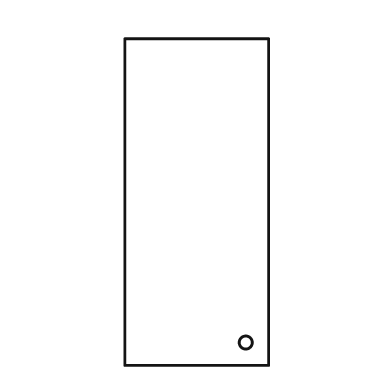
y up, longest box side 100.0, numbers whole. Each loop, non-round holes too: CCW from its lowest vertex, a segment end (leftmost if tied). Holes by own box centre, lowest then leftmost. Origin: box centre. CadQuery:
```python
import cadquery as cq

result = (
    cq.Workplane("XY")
    .moveTo(-22.0, -50.0)
    .lineTo(22.0, -50.0)
    .lineTo(22.0, 50.0)
    .lineTo(-22.0, 50.0)
    .close()
    .moveTo(15.0, -43.0)
    .circle(2.0)
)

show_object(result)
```